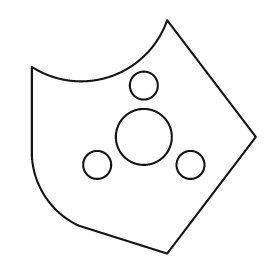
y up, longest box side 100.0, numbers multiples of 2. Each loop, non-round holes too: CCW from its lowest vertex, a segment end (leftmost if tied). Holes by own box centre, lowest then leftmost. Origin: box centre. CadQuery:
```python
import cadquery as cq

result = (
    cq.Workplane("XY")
    .moveTo(10.0, -50.0)
    .lineTo(48.0, 0.0)
    .lineTo(10.0, 50.0)
    .threePointArc((-14.0, 26.0), (-48.0, 30.0))
    .lineTo(-48.0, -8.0)
    .threePointArc((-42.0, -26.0), (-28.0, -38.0))
    .close()
    .moveTo(-20.0, -12.0)
    .circle(6.0)
    .moveTo(20.0, -12.0)
    .circle(6.0)
    .moveTo(0.0, 0.0)
    .circle(12.0)
    .moveTo(0.0, 22.0)
    .circle(6.0)
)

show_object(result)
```